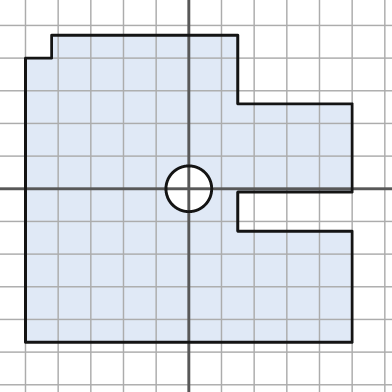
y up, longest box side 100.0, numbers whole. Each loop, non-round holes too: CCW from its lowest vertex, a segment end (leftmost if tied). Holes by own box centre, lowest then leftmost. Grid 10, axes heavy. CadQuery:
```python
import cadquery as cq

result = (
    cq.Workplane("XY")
    .moveTo(-50.0, -47.0)
    .lineTo(50.0, -47.0)
    .lineTo(50.0, -13.0)
    .lineTo(15.0, -13.0)
    .lineTo(15.0, -1.0)
    .lineTo(50.0, -1.0)
    .lineTo(50.0, 26.0)
    .lineTo(15.0, 26.0)
    .lineTo(15.0, 47.0)
    .lineTo(-42.0, 47.0)
    .lineTo(-42.0, 40.0)
    .lineTo(-50.0, 40.0)
    .close()
    .moveTo(0.0, 0.0)
    .circle(7.0)
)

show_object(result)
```